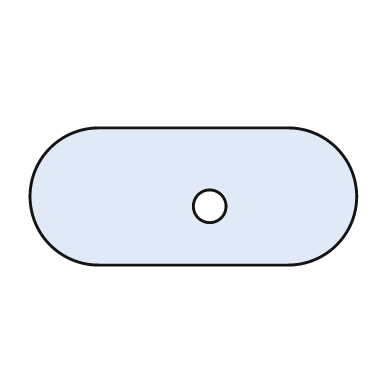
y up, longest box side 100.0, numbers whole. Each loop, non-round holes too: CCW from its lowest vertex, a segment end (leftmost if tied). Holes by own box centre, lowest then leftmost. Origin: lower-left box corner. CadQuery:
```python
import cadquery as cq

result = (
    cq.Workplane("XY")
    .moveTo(21.0, 0.0)
    .lineTo(79.0, 0.0)
    .threePointArc((100.0, 21.0), (79.0, 42.0))
    .lineTo(21.0, 42.0)
    .threePointArc((0.0, 21.0), (21.0, 0.0))
    .close()
    .moveTo(55.0, 18.0)
    .circle(5.0)
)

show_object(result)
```